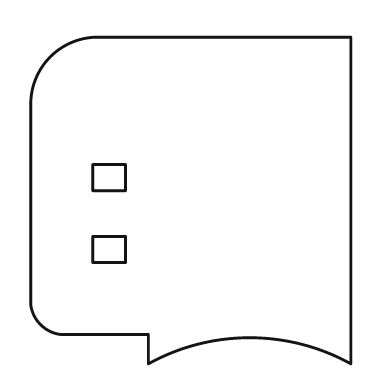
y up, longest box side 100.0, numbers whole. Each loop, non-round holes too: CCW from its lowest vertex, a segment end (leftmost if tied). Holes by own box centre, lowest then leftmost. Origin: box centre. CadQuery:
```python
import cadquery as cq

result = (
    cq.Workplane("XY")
    .moveTo(-13.0, -50.0)
    .threePointArc((18.0, -42.0), (49.0, -50.0))
    .lineTo(49.0, 50.0)
    .lineTo(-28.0, 50.0)
    .threePointArc((-43.0, 44.0), (-49.0, 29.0))
    .lineTo(-49.0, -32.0)
    .threePointArc((-46.0, -38.0), (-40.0, -41.0))
    .lineTo(-13.0, -41.0)
    .close()
    .moveTo(-30.0, -19.0)
    .lineTo(-20.0, -19.0)
    .lineTo(-20.0, -11.0)
    .lineTo(-30.0, -11.0)
    .close()
    .moveTo(-30.0, 3.0)
    .lineTo(-20.0, 3.0)
    .lineTo(-20.0, 11.0)
    .lineTo(-30.0, 11.0)
    .close()
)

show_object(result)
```